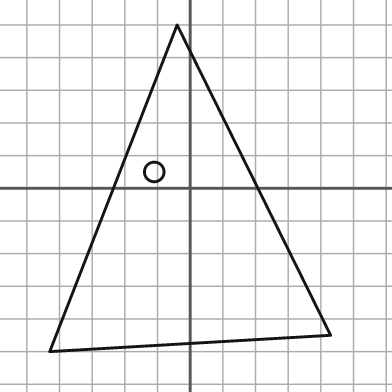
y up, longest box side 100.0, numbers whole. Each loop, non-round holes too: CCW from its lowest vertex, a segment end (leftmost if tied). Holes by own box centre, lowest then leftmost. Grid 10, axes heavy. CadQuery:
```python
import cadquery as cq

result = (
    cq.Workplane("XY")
    .moveTo(-43.0, -50.0)
    .lineTo(43.0, -45.0)
    .lineTo(-4.0, 50.0)
    .close()
    .moveTo(-11.0, 5.0)
    .circle(3.0)
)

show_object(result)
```